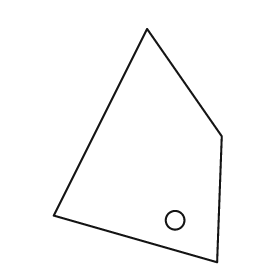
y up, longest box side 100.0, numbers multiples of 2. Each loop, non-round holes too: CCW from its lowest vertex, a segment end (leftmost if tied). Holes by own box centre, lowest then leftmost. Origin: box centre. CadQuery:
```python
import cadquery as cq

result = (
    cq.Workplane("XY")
    .moveTo(34.0, -50.0)
    .lineTo(36.0, 4.0)
    .lineTo(4.0, 50.0)
    .lineTo(-36.0, -30.0)
    .close()
    .moveTo(16.0, -32.0)
    .circle(4.0)
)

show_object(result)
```